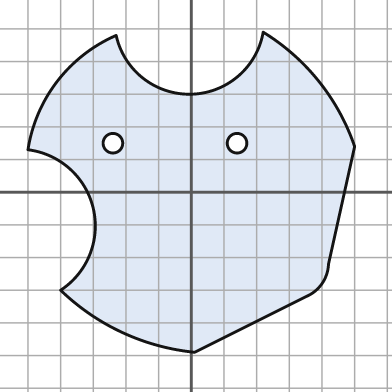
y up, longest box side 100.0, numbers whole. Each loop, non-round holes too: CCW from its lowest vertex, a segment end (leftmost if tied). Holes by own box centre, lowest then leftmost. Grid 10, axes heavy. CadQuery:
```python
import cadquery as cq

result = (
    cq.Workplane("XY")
    .moveTo(1.0, -49.0)
    .lineTo(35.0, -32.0)
    .threePointArc((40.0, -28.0), (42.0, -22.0))
    .lineTo(50.0, 14.0)
    .threePointArc((39.0, 34.0), (22.0, 49.0))
    .threePointArc((0.0, 30.0), (-23.0, 48.0))
    .threePointArc((-41.0, 34.0), (-50.0, 13.0))
    .threePointArc((-30.0, -5.0), (-40.0, -30.0))
    .threePointArc((-21.0, -43.0), (1.0, -49.0))
    .close()
    .moveTo(-24.0, 15.0)
    .circle(3.0)
    .moveTo(14.0, 15.0)
    .circle(3.0)
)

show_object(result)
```